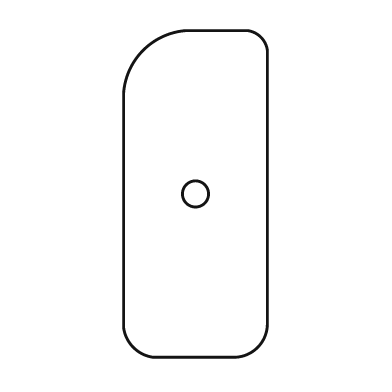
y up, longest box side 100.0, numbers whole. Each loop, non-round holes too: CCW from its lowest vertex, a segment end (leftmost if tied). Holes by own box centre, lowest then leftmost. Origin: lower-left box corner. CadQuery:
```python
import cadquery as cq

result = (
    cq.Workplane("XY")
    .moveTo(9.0, 0.0)
    .lineTo(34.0, 0.0)
    .threePointArc((41.0, 3.0), (44.0, 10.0))
    .lineTo(44.0, 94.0)
    .threePointArc((42.0, 98.0), (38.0, 100.0))
    .lineTo(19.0, 100.0)
    .threePointArc((6.0, 94.0), (0.0, 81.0))
    .lineTo(0.0, 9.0)
    .threePointArc((3.0, 3.0), (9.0, 0.0))
    .close()
    .moveTo(22.0, 50.0)
    .circle(4.0)
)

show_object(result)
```